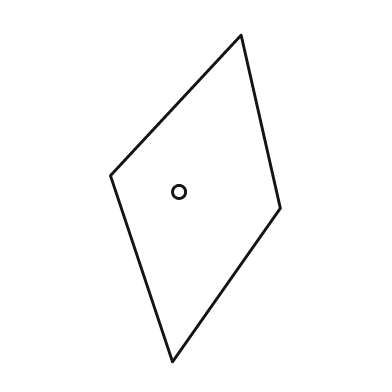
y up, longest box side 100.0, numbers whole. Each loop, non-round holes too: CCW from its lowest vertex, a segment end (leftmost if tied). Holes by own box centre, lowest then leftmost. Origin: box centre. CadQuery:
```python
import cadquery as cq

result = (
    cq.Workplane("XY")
    .moveTo(-7.0, -50.0)
    .lineTo(26.0, -3.0)
    .lineTo(14.0, 50.0)
    .lineTo(-26.0, 7.0)
    .close()
    .moveTo(-5.0, 2.0)
    .circle(2.0)
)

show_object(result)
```